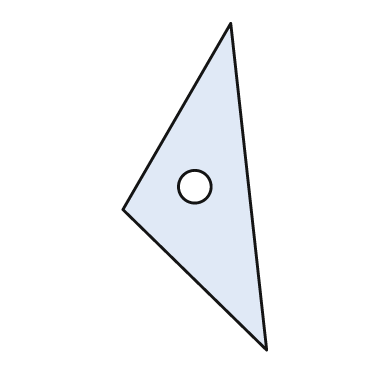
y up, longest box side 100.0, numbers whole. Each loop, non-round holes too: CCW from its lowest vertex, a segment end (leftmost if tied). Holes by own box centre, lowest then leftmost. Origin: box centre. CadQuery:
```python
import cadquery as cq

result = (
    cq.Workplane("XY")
    .moveTo(22.0, -50.0)
    .lineTo(11.0, 50.0)
    .lineTo(-22.0, -7.0)
    .close()
    .moveTo(0.0, 0.0)
    .circle(5.0)
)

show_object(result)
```